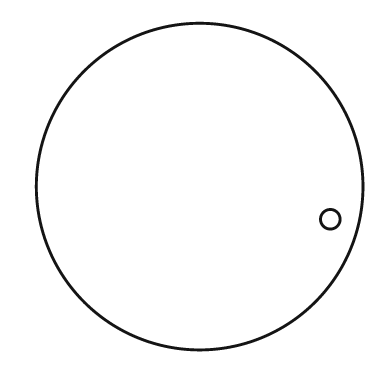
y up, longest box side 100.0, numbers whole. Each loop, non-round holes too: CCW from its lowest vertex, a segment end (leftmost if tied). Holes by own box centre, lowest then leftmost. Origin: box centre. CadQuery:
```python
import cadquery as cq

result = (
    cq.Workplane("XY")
    .moveTo(0.0, 0.0)
    .circle(50.0)
    .moveTo(40.0, -10.0)
    .circle(3.0)
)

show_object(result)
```